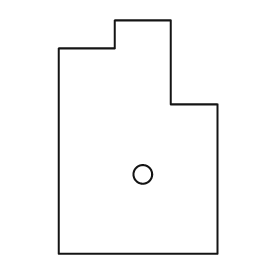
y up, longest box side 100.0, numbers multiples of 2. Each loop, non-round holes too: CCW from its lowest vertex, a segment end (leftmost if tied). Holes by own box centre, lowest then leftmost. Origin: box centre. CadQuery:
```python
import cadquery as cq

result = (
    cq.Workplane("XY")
    .moveTo(-34.0, -50.0)
    .lineTo(34.0, -50.0)
    .lineTo(34.0, 14.0)
    .lineTo(14.0, 14.0)
    .lineTo(14.0, 50.0)
    .lineTo(-10.0, 50.0)
    .lineTo(-10.0, 38.0)
    .lineTo(-34.0, 38.0)
    .close()
    .moveTo(2.0, -16.0)
    .circle(4.0)
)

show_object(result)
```